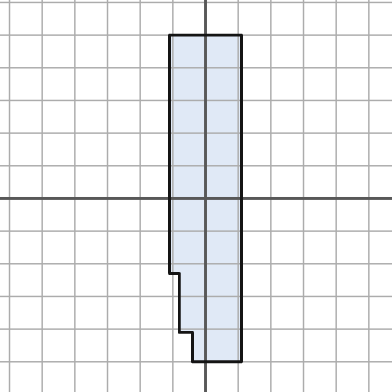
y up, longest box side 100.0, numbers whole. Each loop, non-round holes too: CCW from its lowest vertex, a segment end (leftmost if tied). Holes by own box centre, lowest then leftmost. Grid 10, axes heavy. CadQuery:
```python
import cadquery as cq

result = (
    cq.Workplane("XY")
    .moveTo(-4.0, -50.0)
    .lineTo(11.0, -50.0)
    .lineTo(11.0, 50.0)
    .lineTo(-11.0, 50.0)
    .lineTo(-11.0, -23.0)
    .lineTo(-8.0, -23.0)
    .lineTo(-8.0, -41.0)
    .lineTo(-4.0, -41.0)
    .close()
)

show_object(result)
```